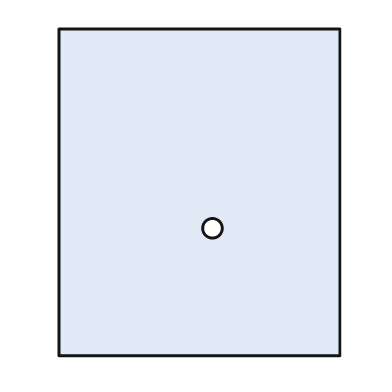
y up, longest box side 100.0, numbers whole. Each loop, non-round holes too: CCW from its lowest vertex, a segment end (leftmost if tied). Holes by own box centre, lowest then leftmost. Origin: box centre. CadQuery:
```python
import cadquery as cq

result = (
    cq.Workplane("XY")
    .moveTo(-43.0, -50.0)
    .lineTo(43.0, -50.0)
    .lineTo(43.0, 50.0)
    .lineTo(-43.0, 50.0)
    .close()
    .moveTo(4.0, -11.0)
    .circle(3.0)
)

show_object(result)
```